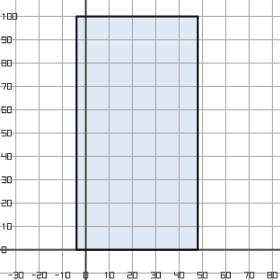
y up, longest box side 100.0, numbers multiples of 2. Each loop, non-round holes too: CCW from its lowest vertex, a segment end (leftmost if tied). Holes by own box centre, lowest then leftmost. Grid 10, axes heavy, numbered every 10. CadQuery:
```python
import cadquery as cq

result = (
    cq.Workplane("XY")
    .moveTo(-4.0, 0.0)
    .lineTo(48.0, 0.0)
    .lineTo(48.0, 100.0)
    .lineTo(-4.0, 100.0)
    .close()
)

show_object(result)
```